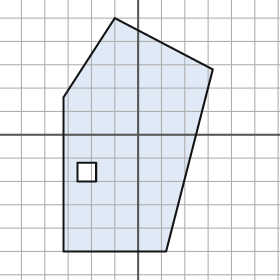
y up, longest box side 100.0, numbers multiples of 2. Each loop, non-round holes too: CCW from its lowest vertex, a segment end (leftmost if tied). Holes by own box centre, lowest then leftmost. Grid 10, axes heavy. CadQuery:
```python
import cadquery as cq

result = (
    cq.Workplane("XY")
    .moveTo(-32.0, -50.0)
    .lineTo(12.0, -50.0)
    .lineTo(32.0, 28.0)
    .lineTo(-10.0, 50.0)
    .lineTo(-32.0, 16.0)
    .close()
    .moveTo(-26.0, -20.0)
    .lineTo(-18.0, -20.0)
    .lineTo(-18.0, -12.0)
    .lineTo(-26.0, -12.0)
    .close()
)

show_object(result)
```